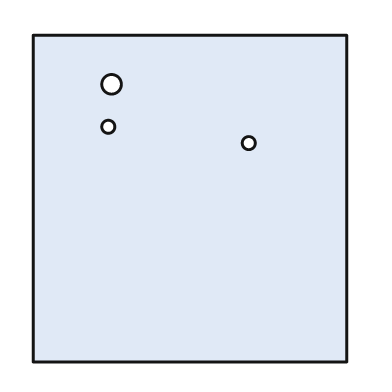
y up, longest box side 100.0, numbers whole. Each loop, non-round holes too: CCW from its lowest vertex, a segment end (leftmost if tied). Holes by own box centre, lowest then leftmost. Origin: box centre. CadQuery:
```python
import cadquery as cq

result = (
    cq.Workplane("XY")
    .moveTo(-48.0, -50.0)
    .lineTo(48.0, -50.0)
    .lineTo(48.0, 50.0)
    .lineTo(-48.0, 50.0)
    .close()
    .moveTo(18.0, 17.0)
    .circle(2.0)
    .moveTo(-25.0, 22.0)
    .circle(2.0)
    .moveTo(-24.0, 35.0)
    .circle(3.0)
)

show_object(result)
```